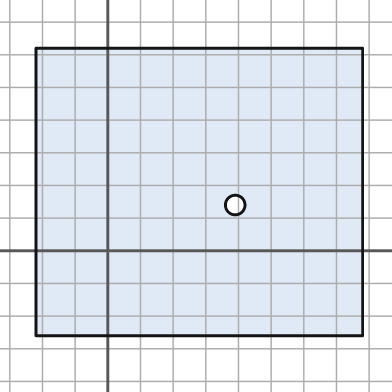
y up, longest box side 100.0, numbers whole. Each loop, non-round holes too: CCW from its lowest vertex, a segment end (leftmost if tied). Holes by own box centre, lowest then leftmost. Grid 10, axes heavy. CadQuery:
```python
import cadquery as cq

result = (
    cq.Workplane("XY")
    .moveTo(-22.0, -26.0)
    .lineTo(78.0, -26.0)
    .lineTo(78.0, 62.0)
    .lineTo(-22.0, 62.0)
    .close()
    .moveTo(39.0, 14.0)
    .circle(3.0)
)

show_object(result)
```